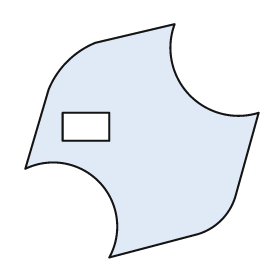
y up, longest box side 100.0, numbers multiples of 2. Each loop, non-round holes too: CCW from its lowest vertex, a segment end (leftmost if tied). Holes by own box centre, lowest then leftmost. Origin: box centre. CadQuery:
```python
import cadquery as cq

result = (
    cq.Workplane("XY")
    .moveTo(-14.0, -50.0)
    .lineTo(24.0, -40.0)
    .threePointArc((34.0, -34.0), (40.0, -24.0))
    .lineTo(50.0, 12.0)
    .threePointArc((20.0, 20.0), (14.0, 50.0))
    .lineTo(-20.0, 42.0)
    .threePointArc((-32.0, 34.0), (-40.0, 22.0))
    .lineTo(-50.0, -12.0)
    .threePointArc((-18.0, -18.0), (-14.0, -50.0))
    .close()
    .moveTo(-34.0, 0.0)
    .lineTo(-14.0, 0.0)
    .lineTo(-14.0, 12.0)
    .lineTo(-34.0, 12.0)
    .close()
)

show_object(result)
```